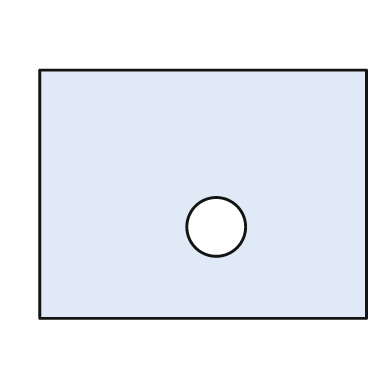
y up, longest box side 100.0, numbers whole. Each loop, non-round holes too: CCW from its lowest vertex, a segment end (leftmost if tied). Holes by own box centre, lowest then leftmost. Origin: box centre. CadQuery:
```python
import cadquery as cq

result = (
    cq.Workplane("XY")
    .moveTo(-50.0, -38.0)
    .lineTo(50.0, -38.0)
    .lineTo(50.0, 38.0)
    .lineTo(-50.0, 38.0)
    .close()
    .moveTo(4.0, -10.0)
    .circle(9.0)
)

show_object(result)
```